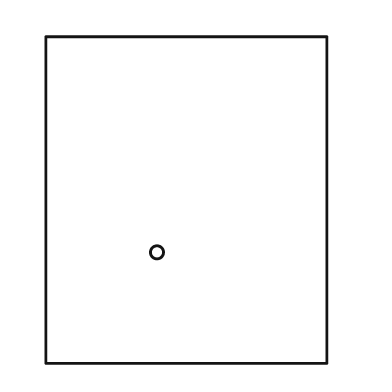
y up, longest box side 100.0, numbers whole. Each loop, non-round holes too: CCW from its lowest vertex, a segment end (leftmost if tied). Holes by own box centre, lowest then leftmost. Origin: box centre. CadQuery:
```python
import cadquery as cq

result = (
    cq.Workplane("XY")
    .moveTo(-43.0, -50.0)
    .lineTo(43.0, -50.0)
    .lineTo(43.0, 50.0)
    .lineTo(-43.0, 50.0)
    .close()
    .moveTo(-9.0, -16.0)
    .circle(2.0)
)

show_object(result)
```